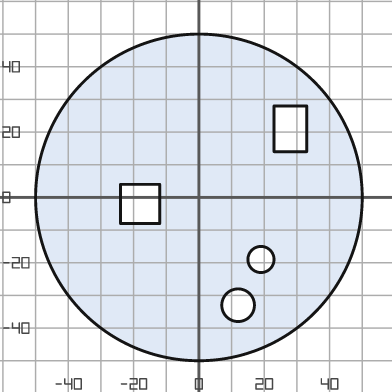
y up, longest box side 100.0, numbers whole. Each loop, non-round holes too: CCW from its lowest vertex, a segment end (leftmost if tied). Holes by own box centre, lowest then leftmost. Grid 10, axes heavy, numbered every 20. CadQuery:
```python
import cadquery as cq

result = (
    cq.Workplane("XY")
    .moveTo(0.0, 0.0)
    .circle(50.0)
    .moveTo(12.0, -33.0)
    .circle(5.0)
    .moveTo(19.0, -19.0)
    .circle(4.0)
    .moveTo(-24.0, -8.0)
    .lineTo(-12.0, -8.0)
    .lineTo(-12.0, 4.0)
    .lineTo(-24.0, 4.0)
    .close()
    .moveTo(23.0, 14.0)
    .lineTo(33.0, 14.0)
    .lineTo(33.0, 28.0)
    .lineTo(23.0, 28.0)
    .close()
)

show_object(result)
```